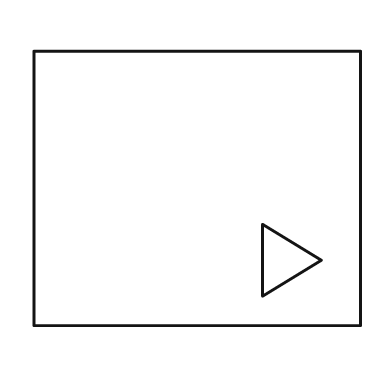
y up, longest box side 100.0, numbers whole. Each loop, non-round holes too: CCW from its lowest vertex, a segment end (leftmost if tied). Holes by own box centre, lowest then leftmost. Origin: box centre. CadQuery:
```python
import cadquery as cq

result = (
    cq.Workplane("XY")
    .moveTo(-50.0, -42.0)
    .lineTo(50.0, -42.0)
    .lineTo(50.0, 42.0)
    .lineTo(-50.0, 42.0)
    .close()
    .moveTo(20.0, -33.0)
    .lineTo(38.0, -22.0)
    .lineTo(20.0, -11.0)
    .close()
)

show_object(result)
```